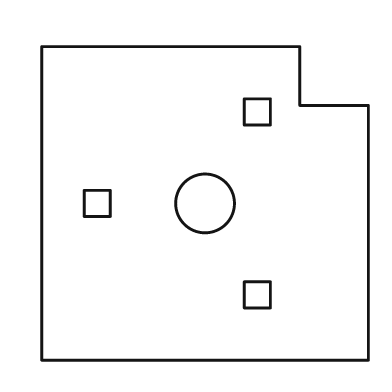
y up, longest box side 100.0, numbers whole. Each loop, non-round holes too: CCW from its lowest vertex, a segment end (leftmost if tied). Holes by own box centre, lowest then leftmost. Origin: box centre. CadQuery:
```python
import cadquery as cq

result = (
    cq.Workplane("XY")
    .moveTo(-50.0, -48.0)
    .lineTo(50.0, -48.0)
    .lineTo(50.0, 30.0)
    .lineTo(29.0, 30.0)
    .lineTo(29.0, 48.0)
    .lineTo(-50.0, 48.0)
    .close()
    .moveTo(12.0, -32.0)
    .lineTo(20.0, -32.0)
    .lineTo(20.0, -24.0)
    .lineTo(12.0, -24.0)
    .close()
    .moveTo(-37.0, -4.0)
    .lineTo(-29.0, -4.0)
    .lineTo(-29.0, 4.0)
    .lineTo(-37.0, 4.0)
    .close()
    .moveTo(0.0, 0.0)
    .circle(9.0)
    .moveTo(12.0, 24.0)
    .lineTo(20.0, 24.0)
    .lineTo(20.0, 32.0)
    .lineTo(12.0, 32.0)
    .close()
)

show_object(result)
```